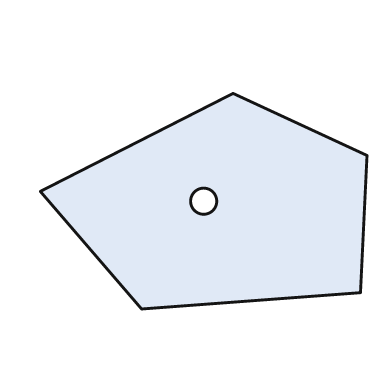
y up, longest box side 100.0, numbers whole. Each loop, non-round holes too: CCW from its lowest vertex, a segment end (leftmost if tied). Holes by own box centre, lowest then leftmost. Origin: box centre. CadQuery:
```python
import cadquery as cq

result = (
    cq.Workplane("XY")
    .moveTo(-19.0, -33.0)
    .lineTo(48.0, -28.0)
    .lineTo(50.0, 14.0)
    .lineTo(9.0, 33.0)
    .lineTo(-50.0, 3.0)
    .close()
    .moveTo(0.0, 0.0)
    .circle(4.0)
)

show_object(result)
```